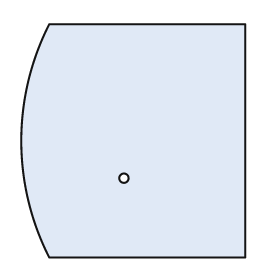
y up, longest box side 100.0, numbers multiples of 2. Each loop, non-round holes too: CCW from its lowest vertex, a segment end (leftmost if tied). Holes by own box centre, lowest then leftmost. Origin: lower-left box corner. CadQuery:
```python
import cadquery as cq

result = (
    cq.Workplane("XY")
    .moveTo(12.0, 0.0)
    .lineTo(96.0, 0.0)
    .lineTo(96.0, 100.0)
    .lineTo(12.0, 100.0)
    .threePointArc((0.0, 50.0), (12.0, 0.0))
    .close()
    .moveTo(44.0, 34.0)
    .circle(2.0)
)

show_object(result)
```